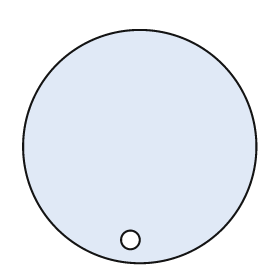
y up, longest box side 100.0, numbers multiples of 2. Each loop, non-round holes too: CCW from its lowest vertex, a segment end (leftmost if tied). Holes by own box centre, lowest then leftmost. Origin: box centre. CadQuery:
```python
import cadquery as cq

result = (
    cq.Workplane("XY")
    .moveTo(0.0, 0.0)
    .circle(50.0)
    .moveTo(-4.0, -40.0)
    .circle(4.0)
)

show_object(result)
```